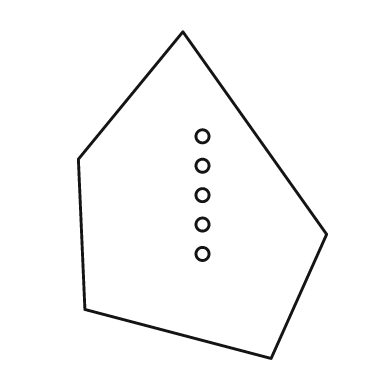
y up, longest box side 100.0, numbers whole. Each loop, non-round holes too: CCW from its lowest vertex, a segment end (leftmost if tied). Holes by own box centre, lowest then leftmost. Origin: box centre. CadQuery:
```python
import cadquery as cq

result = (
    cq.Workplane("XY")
    .moveTo(21.0, -50.0)
    .lineTo(38.0, -12.0)
    .lineTo(-6.0, 50.0)
    .lineTo(-38.0, 11.0)
    .lineTo(-36.0, -35.0)
    .close()
    .moveTo(0.0, -18.0)
    .circle(2.0)
    .moveTo(0.0, -9.0)
    .circle(2.0)
    .moveTo(0.0, 0.0)
    .circle(2.0)
    .moveTo(0.0, 9.0)
    .circle(2.0)
    .moveTo(0.0, 18.0)
    .circle(2.0)
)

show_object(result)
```